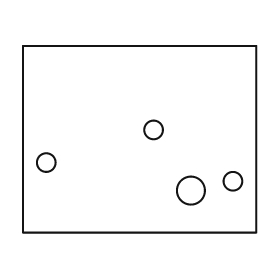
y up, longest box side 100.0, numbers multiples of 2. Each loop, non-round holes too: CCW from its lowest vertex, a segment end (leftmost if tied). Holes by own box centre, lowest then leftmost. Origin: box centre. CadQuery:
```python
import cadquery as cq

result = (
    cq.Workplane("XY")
    .moveTo(-50.0, -40.0)
    .lineTo(50.0, -40.0)
    .lineTo(50.0, 40.0)
    .lineTo(-50.0, 40.0)
    .close()
    .moveTo(22.0, -22.0)
    .circle(6.0)
    .moveTo(40.0, -18.0)
    .circle(4.0)
    .moveTo(-40.0, -10.0)
    .circle(4.0)
    .moveTo(6.0, 4.0)
    .circle(4.0)
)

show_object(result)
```